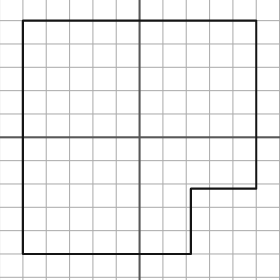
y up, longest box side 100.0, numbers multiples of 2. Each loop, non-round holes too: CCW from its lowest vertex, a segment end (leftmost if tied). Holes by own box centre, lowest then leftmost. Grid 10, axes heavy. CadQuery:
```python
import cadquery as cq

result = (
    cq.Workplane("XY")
    .moveTo(-50.0, -50.0)
    .lineTo(22.0, -50.0)
    .lineTo(22.0, -22.0)
    .lineTo(50.0, -22.0)
    .lineTo(50.0, 50.0)
    .lineTo(-50.0, 50.0)
    .close()
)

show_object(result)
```